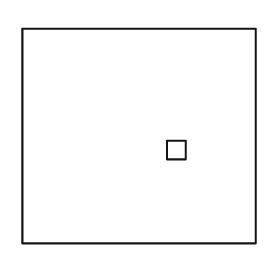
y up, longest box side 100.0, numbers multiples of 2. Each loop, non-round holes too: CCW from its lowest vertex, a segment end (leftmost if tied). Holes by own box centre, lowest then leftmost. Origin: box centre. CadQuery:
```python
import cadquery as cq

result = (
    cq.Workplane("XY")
    .moveTo(-50.0, -46.0)
    .lineTo(50.0, -46.0)
    .lineTo(50.0, 46.0)
    .lineTo(-50.0, 46.0)
    .close()
    .moveTo(12.0, -10.0)
    .lineTo(20.0, -10.0)
    .lineTo(20.0, -2.0)
    .lineTo(12.0, -2.0)
    .close()
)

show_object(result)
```